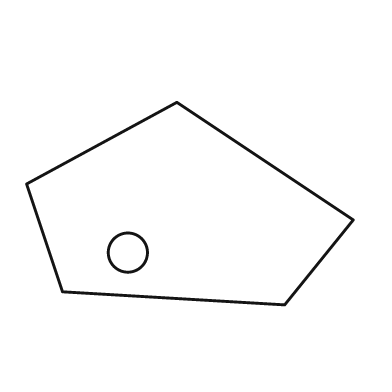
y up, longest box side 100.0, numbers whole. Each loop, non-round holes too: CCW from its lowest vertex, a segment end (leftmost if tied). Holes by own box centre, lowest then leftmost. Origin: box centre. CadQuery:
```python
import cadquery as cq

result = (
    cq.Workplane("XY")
    .moveTo(29.0, -31.0)
    .lineTo(50.0, -5.0)
    .lineTo(-4.0, 31.0)
    .lineTo(-50.0, 6.0)
    .lineTo(-39.0, -27.0)
    .close()
    .moveTo(-19.0, -15.0)
    .circle(6.0)
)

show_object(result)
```